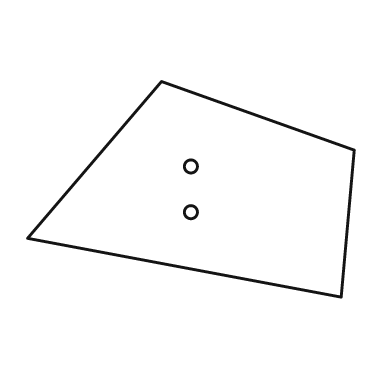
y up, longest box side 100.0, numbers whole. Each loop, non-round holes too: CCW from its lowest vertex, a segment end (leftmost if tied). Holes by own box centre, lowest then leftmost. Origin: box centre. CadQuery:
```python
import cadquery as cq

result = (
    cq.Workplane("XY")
    .moveTo(46.0, -33.0)
    .lineTo(50.0, 12.0)
    .lineTo(-9.0, 33.0)
    .lineTo(-50.0, -15.0)
    .close()
    .moveTo(0.0, -7.0)
    .circle(2.0)
    .moveTo(0.0, 7.0)
    .circle(2.0)
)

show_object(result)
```